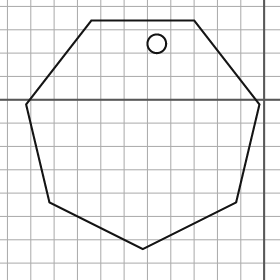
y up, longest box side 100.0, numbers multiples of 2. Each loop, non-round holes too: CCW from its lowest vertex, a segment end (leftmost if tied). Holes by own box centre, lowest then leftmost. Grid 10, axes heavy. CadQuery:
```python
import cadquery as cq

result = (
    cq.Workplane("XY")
    .moveTo(-52.0, -64.0)
    .lineTo(-12.0, -44.0)
    .lineTo(-2.0, -2.0)
    .lineTo(-30.0, 34.0)
    .lineTo(-74.0, 34.0)
    .lineTo(-102.0, -2.0)
    .lineTo(-92.0, -44.0)
    .close()
    .moveTo(-46.0, 24.0)
    .circle(4.0)
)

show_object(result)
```